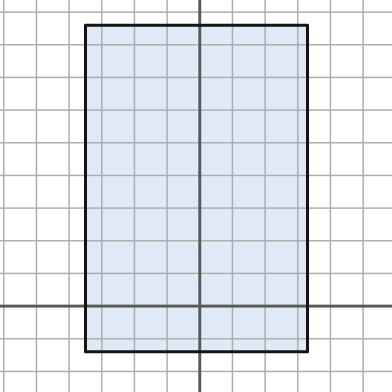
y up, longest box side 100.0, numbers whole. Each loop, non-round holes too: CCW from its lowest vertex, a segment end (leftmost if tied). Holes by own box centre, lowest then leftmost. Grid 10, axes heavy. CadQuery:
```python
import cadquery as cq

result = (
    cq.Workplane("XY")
    .moveTo(-35.0, -14.0)
    .lineTo(33.0, -14.0)
    .lineTo(33.0, 86.0)
    .lineTo(-35.0, 86.0)
    .close()
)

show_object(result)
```